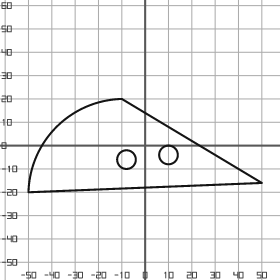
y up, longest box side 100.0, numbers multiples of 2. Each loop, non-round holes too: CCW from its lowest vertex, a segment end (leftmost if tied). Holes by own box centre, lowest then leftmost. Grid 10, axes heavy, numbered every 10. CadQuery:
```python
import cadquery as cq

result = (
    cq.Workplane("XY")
    .moveTo(-50.0, -20.0)
    .lineTo(50.0, -16.0)
    .lineTo(-10.0, 20.0)
    .threePointArc((-38.0, 8.0), (-50.0, -20.0))
    .close()
    .moveTo(-8.0, -6.0)
    .circle(4.0)
    .moveTo(10.0, -4.0)
    .circle(4.0)
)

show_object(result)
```